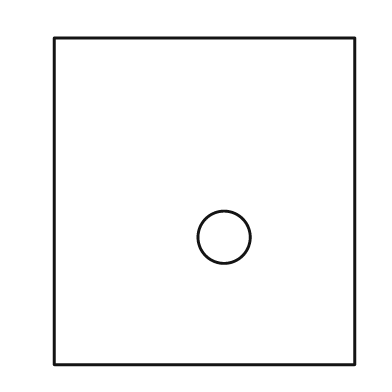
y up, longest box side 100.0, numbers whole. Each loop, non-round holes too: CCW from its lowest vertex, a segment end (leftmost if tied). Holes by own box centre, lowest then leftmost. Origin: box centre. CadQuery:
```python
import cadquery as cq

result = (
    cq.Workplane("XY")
    .moveTo(-46.0, -50.0)
    .lineTo(46.0, -50.0)
    .lineTo(46.0, 50.0)
    .lineTo(-46.0, 50.0)
    .close()
    .moveTo(6.0, -11.0)
    .circle(8.0)
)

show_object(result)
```